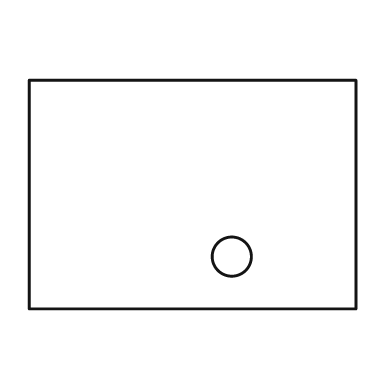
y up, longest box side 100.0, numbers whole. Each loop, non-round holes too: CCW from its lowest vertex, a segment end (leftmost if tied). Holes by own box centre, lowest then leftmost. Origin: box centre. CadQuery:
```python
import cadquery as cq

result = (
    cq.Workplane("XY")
    .moveTo(-50.0, -35.0)
    .lineTo(50.0, -35.0)
    .lineTo(50.0, 35.0)
    .lineTo(-50.0, 35.0)
    .close()
    .moveTo(12.0, -19.0)
    .circle(6.0)
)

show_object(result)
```